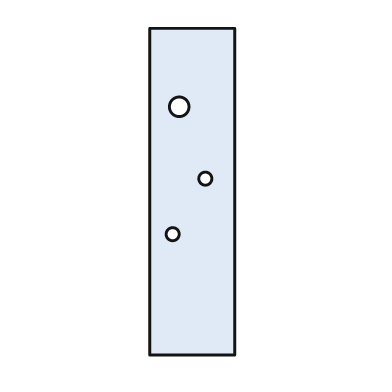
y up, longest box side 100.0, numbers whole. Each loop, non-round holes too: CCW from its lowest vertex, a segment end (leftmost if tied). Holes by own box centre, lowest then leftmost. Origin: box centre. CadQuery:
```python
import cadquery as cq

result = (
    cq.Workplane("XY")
    .moveTo(-13.0, -50.0)
    .lineTo(13.0, -50.0)
    .lineTo(13.0, 50.0)
    .lineTo(-13.0, 50.0)
    .close()
    .moveTo(-6.0, -13.0)
    .circle(2.0)
    .moveTo(4.0, 4.0)
    .circle(2.0)
    .moveTo(-4.0, 26.0)
    .circle(3.0)
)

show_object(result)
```